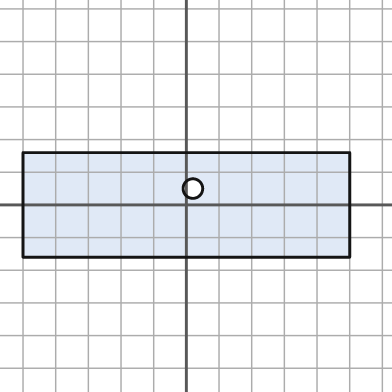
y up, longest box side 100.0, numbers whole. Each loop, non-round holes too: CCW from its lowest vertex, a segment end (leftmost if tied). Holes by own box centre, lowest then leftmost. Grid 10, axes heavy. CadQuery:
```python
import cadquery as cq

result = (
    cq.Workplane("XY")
    .moveTo(-50.0, -16.0)
    .lineTo(50.0, -16.0)
    .lineTo(50.0, 16.0)
    .lineTo(-50.0, 16.0)
    .close()
    .moveTo(2.0, 5.0)
    .circle(3.0)
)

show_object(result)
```